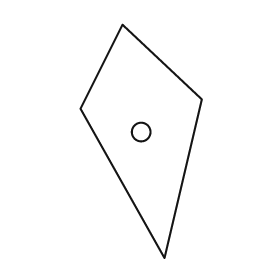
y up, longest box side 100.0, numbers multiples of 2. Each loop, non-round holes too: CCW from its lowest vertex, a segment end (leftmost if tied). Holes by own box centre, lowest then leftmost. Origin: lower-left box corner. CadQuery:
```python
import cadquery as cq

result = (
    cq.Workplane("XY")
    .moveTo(36.0, 0.0)
    .lineTo(52.0, 68.0)
    .lineTo(18.0, 100.0)
    .lineTo(0.0, 64.0)
    .close()
    .moveTo(26.0, 54.0)
    .circle(4.0)
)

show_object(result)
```